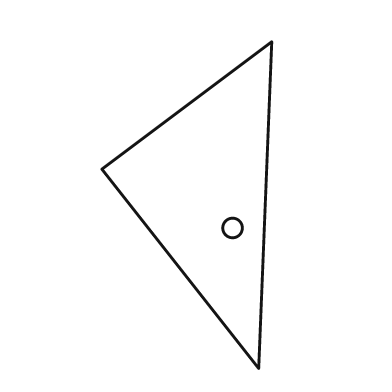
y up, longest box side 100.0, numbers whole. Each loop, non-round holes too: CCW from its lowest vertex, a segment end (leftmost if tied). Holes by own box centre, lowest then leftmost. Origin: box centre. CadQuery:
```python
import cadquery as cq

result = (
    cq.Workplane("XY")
    .moveTo(22.0, -50.0)
    .lineTo(26.0, 50.0)
    .lineTo(-26.0, 11.0)
    .close()
    .moveTo(14.0, -7.0)
    .circle(3.0)
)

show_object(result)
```